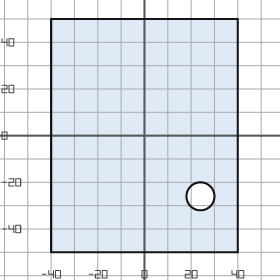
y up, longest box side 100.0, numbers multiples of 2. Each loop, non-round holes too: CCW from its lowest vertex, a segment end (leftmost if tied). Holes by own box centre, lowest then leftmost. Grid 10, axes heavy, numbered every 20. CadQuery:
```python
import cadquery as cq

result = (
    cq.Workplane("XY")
    .moveTo(-40.0, -50.0)
    .lineTo(40.0, -50.0)
    .lineTo(40.0, 50.0)
    .lineTo(-40.0, 50.0)
    .close()
    .moveTo(24.0, -26.0)
    .circle(6.0)
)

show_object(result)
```